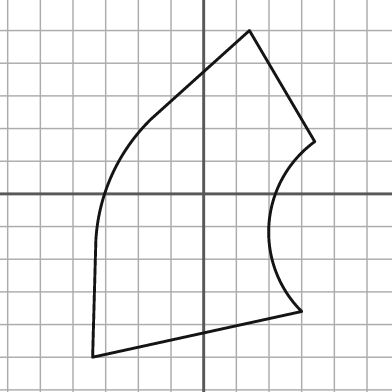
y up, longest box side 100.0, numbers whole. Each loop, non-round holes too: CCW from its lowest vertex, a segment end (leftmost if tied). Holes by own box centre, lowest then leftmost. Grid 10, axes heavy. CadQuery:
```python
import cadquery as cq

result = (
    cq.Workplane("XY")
    .moveTo(-34.0, -50.0)
    .lineTo(30.0, -36.0)
    .threePointArc((20.0, -9.0), (34.0, 16.0))
    .lineTo(14.0, 50.0)
    .lineTo(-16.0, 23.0)
    .threePointArc((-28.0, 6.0), (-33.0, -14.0))
    .close()
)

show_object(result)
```